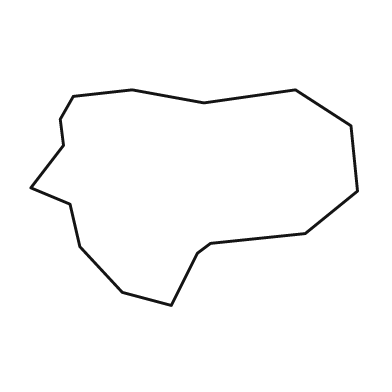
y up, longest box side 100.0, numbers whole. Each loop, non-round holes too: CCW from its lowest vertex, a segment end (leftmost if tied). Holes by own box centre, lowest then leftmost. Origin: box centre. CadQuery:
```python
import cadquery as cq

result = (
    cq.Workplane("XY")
    .moveTo(-7.0, -33.0)
    .lineTo(1.0, -17.0)
    .lineTo(5.0, -14.0)
    .lineTo(34.0, -11.0)
    .lineTo(50.0, 2.0)
    .lineTo(48.0, 22.0)
    .lineTo(31.0, 33.0)
    .lineTo(3.0, 29.0)
    .lineTo(-19.0, 33.0)
    .lineTo(-37.0, 31.0)
    .lineTo(-41.0, 24.0)
    .lineTo(-40.0, 16.0)
    .lineTo(-50.0, 3.0)
    .lineTo(-38.0, -2.0)
    .lineTo(-35.0, -15.0)
    .lineTo(-22.0, -29.0)
    .close()
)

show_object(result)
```